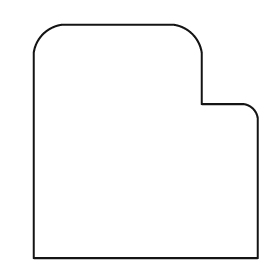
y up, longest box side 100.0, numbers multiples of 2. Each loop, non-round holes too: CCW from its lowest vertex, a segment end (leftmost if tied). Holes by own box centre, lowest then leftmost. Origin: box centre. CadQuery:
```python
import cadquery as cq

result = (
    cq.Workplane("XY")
    .moveTo(-48.0, -50.0)
    .lineTo(48.0, -50.0)
    .lineTo(48.0, 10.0)
    .threePointArc((46.0, 14.0), (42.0, 16.0))
    .lineTo(24.0, 16.0)
    .lineTo(24.0, 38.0)
    .threePointArc((20.0, 46.0), (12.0, 50.0))
    .lineTo(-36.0, 50.0)
    .threePointArc((-44.0, 46.0), (-48.0, 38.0))
    .close()
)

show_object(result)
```